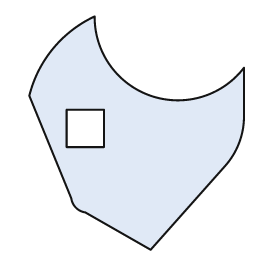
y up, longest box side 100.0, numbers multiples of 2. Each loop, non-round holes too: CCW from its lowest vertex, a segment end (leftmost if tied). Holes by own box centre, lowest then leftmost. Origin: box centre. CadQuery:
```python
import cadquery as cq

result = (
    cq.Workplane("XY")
    .moveTo(6.0, -50.0)
    .lineTo(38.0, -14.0)
    .threePointArc((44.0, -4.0), (46.0, 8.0))
    .lineTo(46.0, 28.0)
    .threePointArc((6.0, 16.0), (-18.0, 50.0))
    .threePointArc((-36.0, 36.0), (-46.0, 16.0))
    .lineTo(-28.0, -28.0)
    .threePointArc((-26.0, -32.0), (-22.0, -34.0))
    .close()
    .moveTo(-30.0, -6.0)
    .lineTo(-14.0, -6.0)
    .lineTo(-14.0, 10.0)
    .lineTo(-30.0, 10.0)
    .close()
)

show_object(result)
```